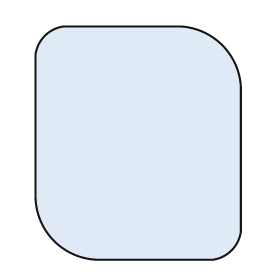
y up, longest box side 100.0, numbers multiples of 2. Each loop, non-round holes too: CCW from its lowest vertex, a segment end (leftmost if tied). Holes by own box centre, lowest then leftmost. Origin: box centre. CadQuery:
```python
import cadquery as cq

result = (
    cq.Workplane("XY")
    .moveTo(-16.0, -50.0)
    .lineTo(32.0, -50.0)
    .threePointArc((40.0, -46.0), (44.0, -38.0))
    .lineTo(44.0, 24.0)
    .threePointArc((36.0, 42.0), (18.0, 50.0))
    .lineTo(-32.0, 50.0)
    .threePointArc((-40.0, 46.0), (-44.0, 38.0))
    .lineTo(-44.0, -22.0)
    .threePointArc((-36.0, -42.0), (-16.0, -50.0))
    .close()
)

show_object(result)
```